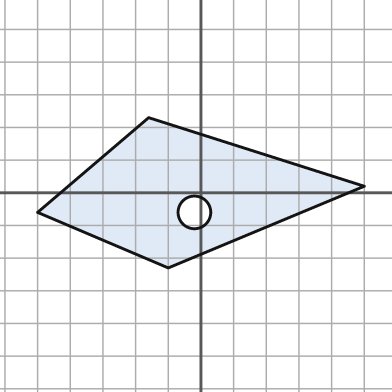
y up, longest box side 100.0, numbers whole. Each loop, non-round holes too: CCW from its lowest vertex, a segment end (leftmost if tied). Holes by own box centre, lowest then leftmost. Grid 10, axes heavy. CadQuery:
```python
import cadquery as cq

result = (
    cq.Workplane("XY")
    .moveTo(-10.0, -23.0)
    .lineTo(50.0, 2.0)
    .lineTo(-16.0, 23.0)
    .lineTo(-50.0, -6.0)
    .close()
    .moveTo(-2.0, -6.0)
    .circle(5.0)
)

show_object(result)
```